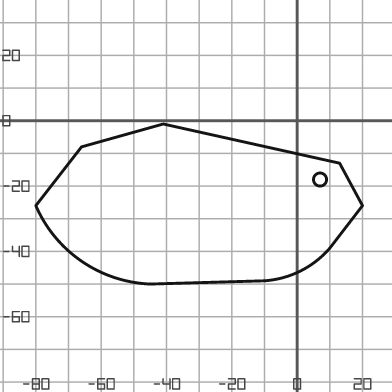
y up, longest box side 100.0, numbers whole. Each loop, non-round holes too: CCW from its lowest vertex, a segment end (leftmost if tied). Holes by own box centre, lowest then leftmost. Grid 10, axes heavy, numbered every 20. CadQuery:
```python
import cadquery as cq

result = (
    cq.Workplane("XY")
    .moveTo(-45.0, -50.0)
    .lineTo(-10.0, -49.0)
    .threePointArc((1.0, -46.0), (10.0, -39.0))
    .lineTo(20.0, -26.0)
    .lineTo(13.0, -13.0)
    .lineTo(-41.0, -1.0)
    .lineTo(-66.0, -8.0)
    .lineTo(-80.0, -26.0)
    .threePointArc((-66.0, -43.0), (-45.0, -50.0))
    .close()
    .moveTo(7.0, -18.0)
    .circle(2.0)
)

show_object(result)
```